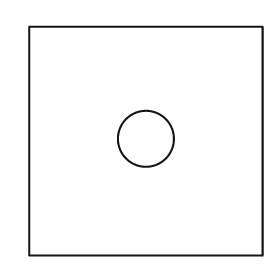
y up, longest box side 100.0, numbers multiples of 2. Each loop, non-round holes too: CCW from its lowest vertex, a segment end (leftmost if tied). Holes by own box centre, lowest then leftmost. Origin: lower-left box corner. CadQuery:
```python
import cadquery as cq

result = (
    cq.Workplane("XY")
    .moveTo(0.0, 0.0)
    .lineTo(100.0, 0.0)
    .lineTo(100.0, 98.0)
    .lineTo(0.0, 98.0)
    .close()
    .moveTo(50.0, 50.0)
    .circle(12.0)
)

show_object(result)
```